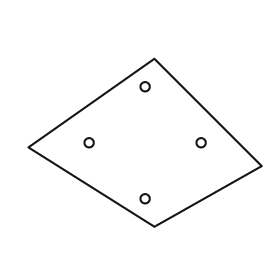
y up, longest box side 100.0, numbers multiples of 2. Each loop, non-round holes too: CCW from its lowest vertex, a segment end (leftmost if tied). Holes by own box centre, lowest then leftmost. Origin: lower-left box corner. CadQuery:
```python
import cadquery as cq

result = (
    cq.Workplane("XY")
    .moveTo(54.0, 0.0)
    .lineTo(100.0, 26.0)
    .lineTo(54.0, 72.0)
    .lineTo(0.0, 34.0)
    .close()
    .moveTo(50.0, 12.0)
    .circle(2.0)
    .moveTo(26.0, 36.0)
    .circle(2.0)
    .moveTo(74.0, 36.0)
    .circle(2.0)
    .moveTo(50.0, 60.0)
    .circle(2.0)
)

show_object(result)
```